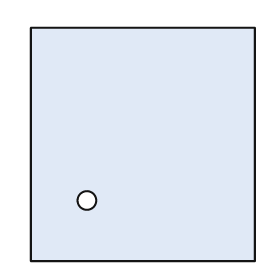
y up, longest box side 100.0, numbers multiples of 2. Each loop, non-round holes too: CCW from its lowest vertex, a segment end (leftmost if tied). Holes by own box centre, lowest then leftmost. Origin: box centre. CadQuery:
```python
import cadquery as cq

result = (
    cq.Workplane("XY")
    .moveTo(-48.0, -50.0)
    .lineTo(48.0, -50.0)
    .lineTo(48.0, 50.0)
    .lineTo(-48.0, 50.0)
    .close()
    .moveTo(-24.0, -24.0)
    .circle(4.0)
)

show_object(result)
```